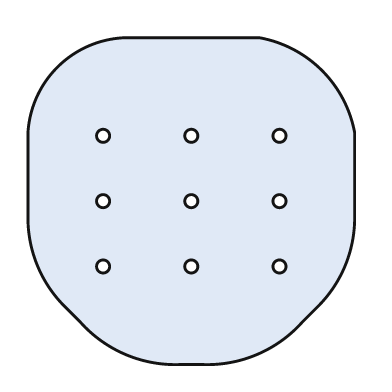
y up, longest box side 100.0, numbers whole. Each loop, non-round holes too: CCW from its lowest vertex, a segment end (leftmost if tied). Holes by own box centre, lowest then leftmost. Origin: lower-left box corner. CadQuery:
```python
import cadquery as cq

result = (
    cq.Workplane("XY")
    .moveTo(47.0, 0.0)
    .lineTo(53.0, 0.0)
    .threePointArc((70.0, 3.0), (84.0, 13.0))
    .lineTo(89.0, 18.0)
    .threePointArc((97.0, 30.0), (100.0, 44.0))
    .lineTo(100.0, 71.0)
    .threePointArc((90.0, 90.0), (71.0, 100.0))
    .lineTo(29.0, 100.0)
    .threePointArc((9.0, 91.0), (0.0, 71.0))
    .lineTo(0.0, 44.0)
    .threePointArc((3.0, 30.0), (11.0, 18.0))
    .lineTo(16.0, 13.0)
    .threePointArc((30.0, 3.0), (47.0, 0.0))
    .close()
    .moveTo(23.0, 30.0)
    .circle(2.0)
    .moveTo(50.0, 30.0)
    .circle(2.0)
    .moveTo(77.0, 30.0)
    .circle(2.0)
    .moveTo(23.0, 50.0)
    .circle(2.0)
    .moveTo(50.0, 50.0)
    .circle(2.0)
    .moveTo(77.0, 50.0)
    .circle(2.0)
    .moveTo(23.0, 70.0)
    .circle(2.0)
    .moveTo(50.0, 70.0)
    .circle(2.0)
    .moveTo(77.0, 70.0)
    .circle(2.0)
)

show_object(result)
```